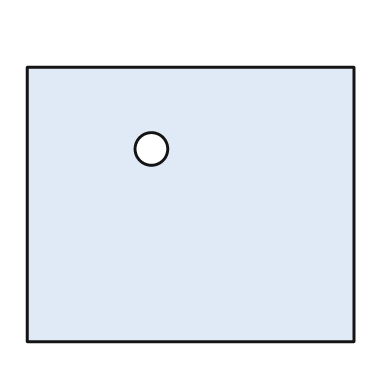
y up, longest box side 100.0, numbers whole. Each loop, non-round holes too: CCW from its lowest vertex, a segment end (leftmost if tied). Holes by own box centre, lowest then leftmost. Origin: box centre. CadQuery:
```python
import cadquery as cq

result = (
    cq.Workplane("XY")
    .moveTo(-50.0, -42.0)
    .lineTo(50.0, -42.0)
    .lineTo(50.0, 42.0)
    .lineTo(-50.0, 42.0)
    .close()
    .moveTo(-12.0, 17.0)
    .circle(5.0)
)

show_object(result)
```